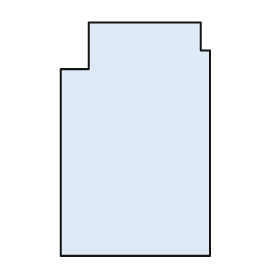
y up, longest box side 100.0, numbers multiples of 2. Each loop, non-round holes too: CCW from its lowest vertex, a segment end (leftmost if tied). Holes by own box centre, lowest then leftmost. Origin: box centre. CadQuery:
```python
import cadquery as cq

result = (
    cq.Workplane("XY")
    .moveTo(-32.0, -50.0)
    .lineTo(32.0, -50.0)
    .lineTo(32.0, 38.0)
    .lineTo(28.0, 38.0)
    .lineTo(28.0, 50.0)
    .lineTo(-20.0, 50.0)
    .lineTo(-20.0, 30.0)
    .lineTo(-32.0, 30.0)
    .close()
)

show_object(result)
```